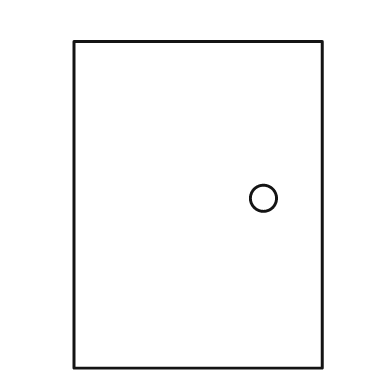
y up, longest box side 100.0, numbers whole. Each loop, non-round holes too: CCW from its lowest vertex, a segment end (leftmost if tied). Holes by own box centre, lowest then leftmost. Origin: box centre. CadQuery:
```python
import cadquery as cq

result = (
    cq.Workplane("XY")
    .moveTo(-38.0, -50.0)
    .lineTo(38.0, -50.0)
    .lineTo(38.0, 50.0)
    .lineTo(-38.0, 50.0)
    .close()
    .moveTo(20.0, 2.0)
    .circle(4.0)
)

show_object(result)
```